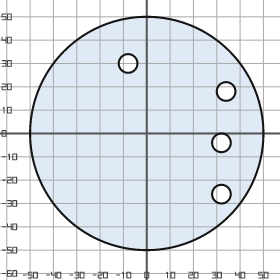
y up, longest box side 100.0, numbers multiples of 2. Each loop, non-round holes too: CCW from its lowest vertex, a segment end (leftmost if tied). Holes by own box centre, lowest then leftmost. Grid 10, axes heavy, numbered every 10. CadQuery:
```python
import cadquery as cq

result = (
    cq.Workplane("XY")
    .moveTo(0.0, 0.0)
    .circle(50.0)
    .moveTo(32.0, -26.0)
    .circle(4.0)
    .moveTo(32.0, -4.0)
    .circle(4.0)
    .moveTo(34.0, 18.0)
    .circle(4.0)
    .moveTo(-8.0, 30.0)
    .circle(4.0)
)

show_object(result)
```